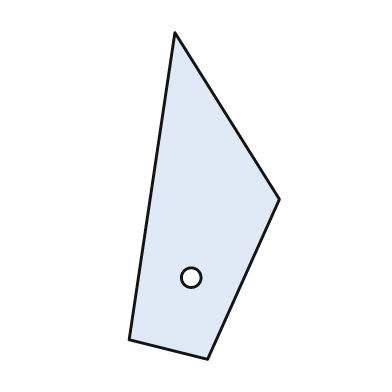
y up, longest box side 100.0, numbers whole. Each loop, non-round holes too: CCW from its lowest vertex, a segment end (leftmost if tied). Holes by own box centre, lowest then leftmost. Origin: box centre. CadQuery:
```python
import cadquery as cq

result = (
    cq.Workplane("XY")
    .moveTo(1.0, -50.0)
    .lineTo(23.0, -1.0)
    .lineTo(-9.0, 50.0)
    .lineTo(-23.0, -44.0)
    .close()
    .moveTo(-4.0, -25.0)
    .circle(3.0)
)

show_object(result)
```